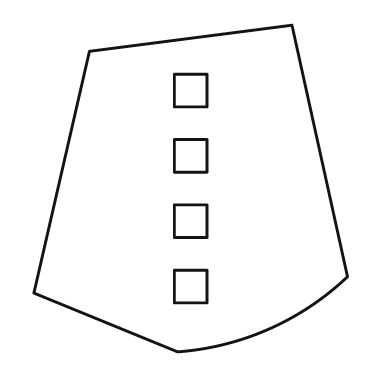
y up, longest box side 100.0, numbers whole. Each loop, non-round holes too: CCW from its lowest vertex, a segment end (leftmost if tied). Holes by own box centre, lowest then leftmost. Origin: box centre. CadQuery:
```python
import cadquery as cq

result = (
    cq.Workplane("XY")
    .moveTo(-4.0, -50.0)
    .threePointArc((24.0, -43.0), (48.0, -27.0))
    .lineTo(31.0, 50.0)
    .lineTo(-31.0, 42.0)
    .lineTo(-48.0, -32.0)
    .close()
    .moveTo(-5.0, -35.0)
    .lineTo(5.0, -35.0)
    .lineTo(5.0, -25.0)
    .lineTo(-5.0, -25.0)
    .close()
    .moveTo(-5.0, -15.0)
    .lineTo(5.0, -15.0)
    .lineTo(5.0, -5.0)
    .lineTo(-5.0, -5.0)
    .close()
    .moveTo(-5.0, 5.0)
    .lineTo(5.0, 5.0)
    .lineTo(5.0, 15.0)
    .lineTo(-5.0, 15.0)
    .close()
    .moveTo(-5.0, 25.0)
    .lineTo(5.0, 25.0)
    .lineTo(5.0, 35.0)
    .lineTo(-5.0, 35.0)
    .close()
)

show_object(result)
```